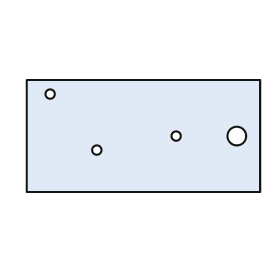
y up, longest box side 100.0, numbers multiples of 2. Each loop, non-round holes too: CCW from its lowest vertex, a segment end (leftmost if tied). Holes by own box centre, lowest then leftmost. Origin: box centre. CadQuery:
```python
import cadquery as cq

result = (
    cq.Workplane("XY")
    .moveTo(-50.0, -24.0)
    .lineTo(50.0, -24.0)
    .lineTo(50.0, 24.0)
    .lineTo(-50.0, 24.0)
    .close()
    .moveTo(-20.0, -6.0)
    .circle(2.0)
    .moveTo(14.0, 0.0)
    .circle(2.0)
    .moveTo(40.0, 0.0)
    .circle(4.0)
    .moveTo(-40.0, 18.0)
    .circle(2.0)
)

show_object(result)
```